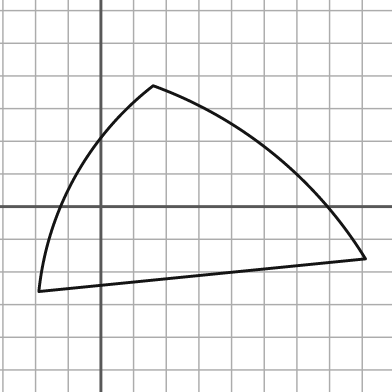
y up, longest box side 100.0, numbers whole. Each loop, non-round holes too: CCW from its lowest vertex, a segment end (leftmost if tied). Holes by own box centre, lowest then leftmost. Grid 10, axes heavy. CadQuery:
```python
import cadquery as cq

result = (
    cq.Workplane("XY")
    .moveTo(-19.0, -26.0)
    .lineTo(81.0, -16.0)
    .threePointArc((53.0, 16.0), (16.0, 37.0))
    .threePointArc((-8.0, 9.0), (-19.0, -26.0))
    .close()
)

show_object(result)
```